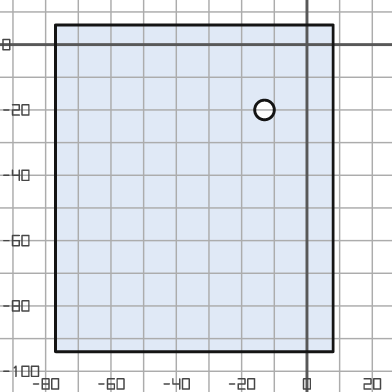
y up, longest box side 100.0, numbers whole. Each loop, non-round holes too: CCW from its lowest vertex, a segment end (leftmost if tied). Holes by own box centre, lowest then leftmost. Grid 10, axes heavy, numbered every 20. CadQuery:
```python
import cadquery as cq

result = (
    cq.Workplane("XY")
    .moveTo(-77.0, -94.0)
    .lineTo(8.0, -94.0)
    .lineTo(8.0, 6.0)
    .lineTo(-77.0, 6.0)
    .close()
    .moveTo(-13.0, -20.0)
    .circle(3.0)
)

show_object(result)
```